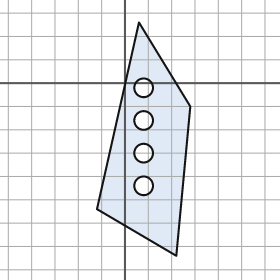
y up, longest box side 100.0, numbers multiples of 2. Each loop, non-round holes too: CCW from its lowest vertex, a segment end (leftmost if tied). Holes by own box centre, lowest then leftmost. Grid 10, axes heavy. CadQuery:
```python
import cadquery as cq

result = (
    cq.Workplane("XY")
    .moveTo(22.0, -74.0)
    .lineTo(28.0, -10.0)
    .lineTo(6.0, 26.0)
    .lineTo(-12.0, -54.0)
    .close()
    .moveTo(8.0, -44.0)
    .circle(4.0)
    .moveTo(8.0, -30.0)
    .circle(4.0)
    .moveTo(8.0, -16.0)
    .circle(4.0)
    .moveTo(8.0, -2.0)
    .circle(4.0)
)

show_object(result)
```